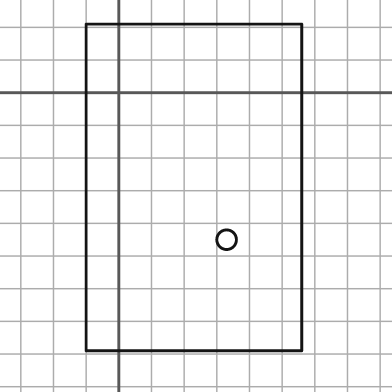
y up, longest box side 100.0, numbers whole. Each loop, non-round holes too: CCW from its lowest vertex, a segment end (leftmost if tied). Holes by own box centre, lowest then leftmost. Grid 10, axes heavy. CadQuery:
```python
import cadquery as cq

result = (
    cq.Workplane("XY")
    .moveTo(-10.0, -79.0)
    .lineTo(56.0, -79.0)
    .lineTo(56.0, 21.0)
    .lineTo(-10.0, 21.0)
    .close()
    .moveTo(33.0, -45.0)
    .circle(3.0)
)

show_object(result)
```